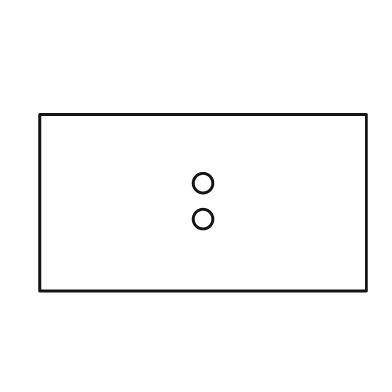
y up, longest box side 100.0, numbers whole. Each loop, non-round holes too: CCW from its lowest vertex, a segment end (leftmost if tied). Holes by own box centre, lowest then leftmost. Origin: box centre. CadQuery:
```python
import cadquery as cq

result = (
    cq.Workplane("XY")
    .moveTo(-50.0, -27.0)
    .lineTo(50.0, -27.0)
    .lineTo(50.0, 27.0)
    .lineTo(-50.0, 27.0)
    .close()
    .moveTo(0.0, -5.0)
    .circle(3.0)
    .moveTo(0.0, 6.0)
    .circle(3.0)
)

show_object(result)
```